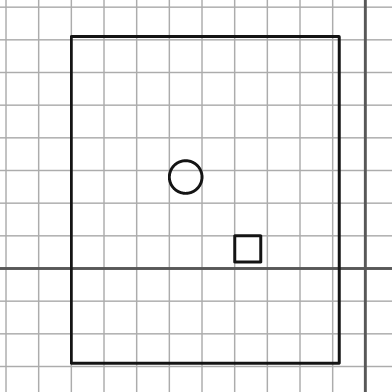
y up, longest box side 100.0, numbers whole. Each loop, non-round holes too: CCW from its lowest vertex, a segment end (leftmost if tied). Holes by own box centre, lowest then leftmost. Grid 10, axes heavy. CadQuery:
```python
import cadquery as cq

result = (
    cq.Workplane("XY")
    .moveTo(-90.0, -29.0)
    .lineTo(-8.0, -29.0)
    .lineTo(-8.0, 71.0)
    .lineTo(-90.0, 71.0)
    .close()
    .moveTo(-40.0, 2.0)
    .lineTo(-32.0, 2.0)
    .lineTo(-32.0, 10.0)
    .lineTo(-40.0, 10.0)
    .close()
    .moveTo(-55.0, 28.0)
    .circle(5.0)
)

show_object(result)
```